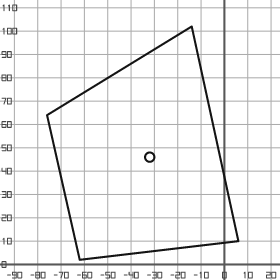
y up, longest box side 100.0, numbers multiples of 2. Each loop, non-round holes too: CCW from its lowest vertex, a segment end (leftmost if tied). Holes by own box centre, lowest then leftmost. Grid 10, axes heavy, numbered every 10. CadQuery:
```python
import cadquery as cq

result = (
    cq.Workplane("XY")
    .moveTo(-62.0, 2.0)
    .lineTo(6.0, 10.0)
    .lineTo(-14.0, 102.0)
    .lineTo(-76.0, 64.0)
    .close()
    .moveTo(-32.0, 46.0)
    .circle(2.0)
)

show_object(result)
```